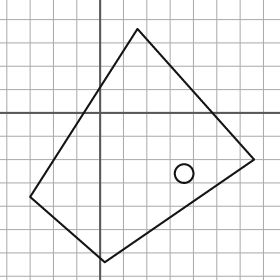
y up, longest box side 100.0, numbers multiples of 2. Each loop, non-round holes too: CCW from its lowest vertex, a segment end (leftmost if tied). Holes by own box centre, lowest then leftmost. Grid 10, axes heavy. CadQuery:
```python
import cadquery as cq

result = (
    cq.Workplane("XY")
    .moveTo(2.0, -64.0)
    .lineTo(66.0, -20.0)
    .lineTo(16.0, 36.0)
    .lineTo(-30.0, -36.0)
    .close()
    .moveTo(36.0, -26.0)
    .circle(4.0)
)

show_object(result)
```